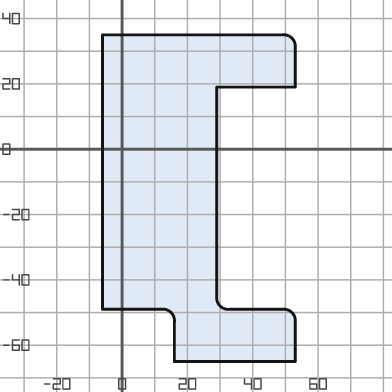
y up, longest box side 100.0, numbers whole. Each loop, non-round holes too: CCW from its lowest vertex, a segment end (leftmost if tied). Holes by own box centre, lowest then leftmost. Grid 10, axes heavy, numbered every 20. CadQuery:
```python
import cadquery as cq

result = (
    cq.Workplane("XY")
    .moveTo(16.0, -65.0)
    .lineTo(53.0, -65.0)
    .lineTo(53.0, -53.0)
    .threePointArc((52.0, -50.0), (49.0, -49.0))
    .lineTo(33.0, -49.0)
    .threePointArc((30.0, -48.0), (29.0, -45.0))
    .lineTo(29.0, 19.0)
    .lineTo(53.0, 19.0)
    .lineTo(53.0, 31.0)
    .threePointArc((52.0, 34.0), (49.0, 35.0))
    .lineTo(-6.0, 35.0)
    .lineTo(-6.0, -49.0)
    .lineTo(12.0, -49.0)
    .threePointArc((15.0, -50.0), (16.0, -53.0))
    .close()
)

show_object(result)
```